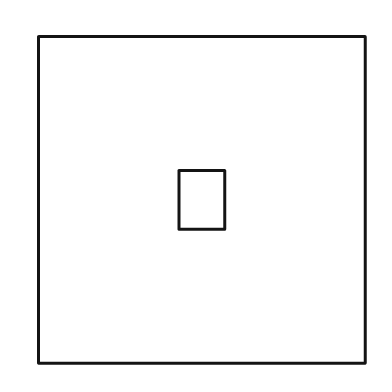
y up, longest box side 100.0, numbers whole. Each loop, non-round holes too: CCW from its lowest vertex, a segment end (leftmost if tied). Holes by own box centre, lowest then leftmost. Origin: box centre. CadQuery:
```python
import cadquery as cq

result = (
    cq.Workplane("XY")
    .moveTo(-50.0, -50.0)
    .lineTo(50.0, -50.0)
    .lineTo(50.0, 50.0)
    .lineTo(-50.0, 50.0)
    .close()
    .moveTo(-7.0, -9.0)
    .lineTo(7.0, -9.0)
    .lineTo(7.0, 9.0)
    .lineTo(-7.0, 9.0)
    .close()
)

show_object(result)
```